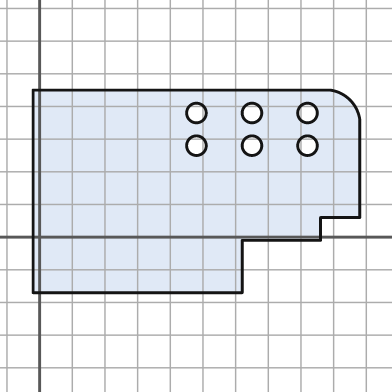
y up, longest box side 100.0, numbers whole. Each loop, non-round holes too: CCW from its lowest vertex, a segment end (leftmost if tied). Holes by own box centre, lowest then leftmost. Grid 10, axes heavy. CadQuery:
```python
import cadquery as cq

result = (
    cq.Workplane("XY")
    .moveTo(-2.0, -17.0)
    .lineTo(62.0, -17.0)
    .lineTo(62.0, -1.0)
    .lineTo(86.0, -1.0)
    .lineTo(86.0, 6.0)
    .lineTo(98.0, 6.0)
    .lineTo(98.0, 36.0)
    .threePointArc((95.0, 42.0), (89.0, 45.0))
    .lineTo(-2.0, 45.0)
    .close()
    .moveTo(48.0, 28.0)
    .circle(3.0)
    .moveTo(65.0, 28.0)
    .circle(3.0)
    .moveTo(82.0, 28.0)
    .circle(3.0)
    .moveTo(48.0, 38.0)
    .circle(3.0)
    .moveTo(65.0, 38.0)
    .circle(3.0)
    .moveTo(82.0, 38.0)
    .circle(3.0)
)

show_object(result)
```